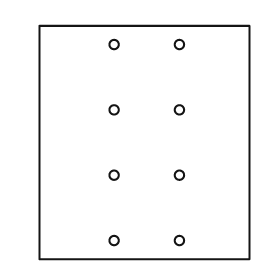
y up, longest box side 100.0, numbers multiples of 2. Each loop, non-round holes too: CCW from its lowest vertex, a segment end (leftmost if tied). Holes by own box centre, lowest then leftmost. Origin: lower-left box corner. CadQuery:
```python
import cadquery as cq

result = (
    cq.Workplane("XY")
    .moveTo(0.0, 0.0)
    .lineTo(90.0, 0.0)
    .lineTo(90.0, 100.0)
    .lineTo(0.0, 100.0)
    .close()
    .moveTo(32.0, 8.0)
    .circle(2.0)
    .moveTo(60.0, 8.0)
    .circle(2.0)
    .moveTo(32.0, 36.0)
    .circle(2.0)
    .moveTo(60.0, 36.0)
    .circle(2.0)
    .moveTo(32.0, 64.0)
    .circle(2.0)
    .moveTo(60.0, 64.0)
    .circle(2.0)
    .moveTo(32.0, 92.0)
    .circle(2.0)
    .moveTo(60.0, 92.0)
    .circle(2.0)
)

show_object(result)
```